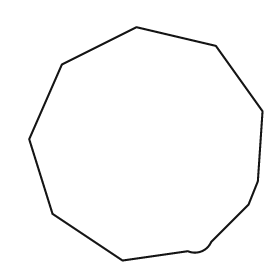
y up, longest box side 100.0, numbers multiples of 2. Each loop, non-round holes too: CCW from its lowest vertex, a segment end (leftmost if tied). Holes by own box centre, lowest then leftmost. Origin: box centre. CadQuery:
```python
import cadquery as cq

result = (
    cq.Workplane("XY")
    .moveTo(-10.0, -50.0)
    .lineTo(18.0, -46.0)
    .threePointArc((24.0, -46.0), (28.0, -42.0))
    .lineTo(44.0, -26.0)
    .lineTo(48.0, -16.0)
    .lineTo(50.0, 14.0)
    .lineTo(30.0, 42.0)
    .lineTo(-4.0, 50.0)
    .lineTo(-36.0, 34.0)
    .lineTo(-50.0, 2.0)
    .lineTo(-40.0, -30.0)
    .close()
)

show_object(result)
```